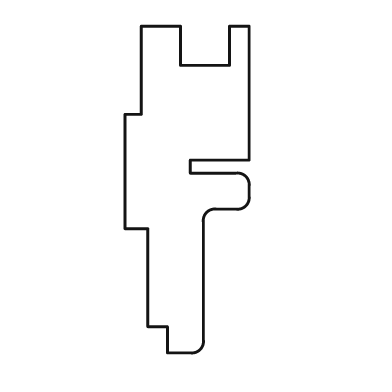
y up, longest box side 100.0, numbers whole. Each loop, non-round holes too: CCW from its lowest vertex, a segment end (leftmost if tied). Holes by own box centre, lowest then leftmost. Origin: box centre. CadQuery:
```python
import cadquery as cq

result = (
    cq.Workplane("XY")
    .moveTo(-6.0, -50.0)
    .lineTo(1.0, -50.0)
    .threePointArc((4.0, -49.0), (5.0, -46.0))
    .lineTo(5.0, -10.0)
    .threePointArc((6.0, -7.0), (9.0, -6.0))
    .lineTo(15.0, -6.0)
    .threePointArc((18.0, -5.0), (19.0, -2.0))
    .lineTo(19.0, 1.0)
    .threePointArc((18.0, 4.0), (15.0, 5.0))
    .lineTo(1.0, 5.0)
    .lineTo(1.0, 9.0)
    .lineTo(19.0, 9.0)
    .lineTo(19.0, 50.0)
    .lineTo(13.0, 50.0)
    .lineTo(13.0, 38.0)
    .lineTo(-2.0, 38.0)
    .lineTo(-2.0, 50.0)
    .lineTo(-14.0, 50.0)
    .lineTo(-14.0, 23.0)
    .lineTo(-19.0, 23.0)
    .lineTo(-19.0, -12.0)
    .lineTo(-12.0, -12.0)
    .lineTo(-12.0, -42.0)
    .lineTo(-6.0, -42.0)
    .close()
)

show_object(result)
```